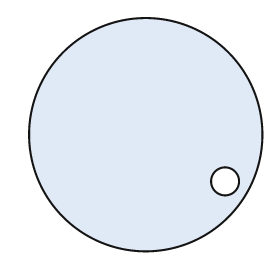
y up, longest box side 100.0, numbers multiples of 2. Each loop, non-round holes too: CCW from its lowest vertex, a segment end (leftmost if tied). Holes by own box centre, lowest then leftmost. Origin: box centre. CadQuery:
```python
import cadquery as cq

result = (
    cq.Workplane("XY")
    .moveTo(0.0, 0.0)
    .circle(50.0)
    .moveTo(34.0, -20.0)
    .circle(6.0)
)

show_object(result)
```